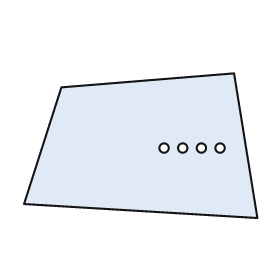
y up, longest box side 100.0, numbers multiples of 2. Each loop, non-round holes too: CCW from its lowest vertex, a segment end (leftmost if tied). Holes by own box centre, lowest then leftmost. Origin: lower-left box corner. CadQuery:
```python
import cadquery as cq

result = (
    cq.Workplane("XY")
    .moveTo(100.0, 0.0)
    .lineTo(90.0, 62.0)
    .lineTo(16.0, 56.0)
    .lineTo(0.0, 6.0)
    .close()
    .moveTo(60.0, 30.0)
    .circle(2.0)
    .moveTo(68.0, 30.0)
    .circle(2.0)
    .moveTo(76.0, 30.0)
    .circle(2.0)
    .moveTo(84.0, 30.0)
    .circle(2.0)
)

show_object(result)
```